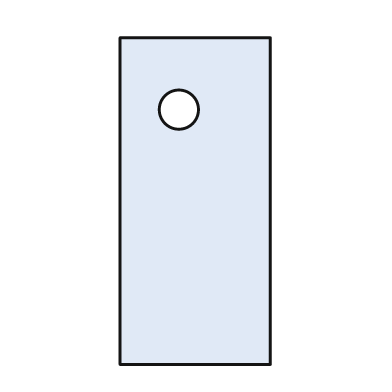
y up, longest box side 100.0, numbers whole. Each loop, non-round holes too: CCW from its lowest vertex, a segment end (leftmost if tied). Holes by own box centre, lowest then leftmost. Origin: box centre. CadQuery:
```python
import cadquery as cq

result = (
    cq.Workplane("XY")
    .moveTo(-23.0, -50.0)
    .lineTo(23.0, -50.0)
    .lineTo(23.0, 50.0)
    .lineTo(-23.0, 50.0)
    .close()
    .moveTo(-5.0, 28.0)
    .circle(6.0)
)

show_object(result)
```